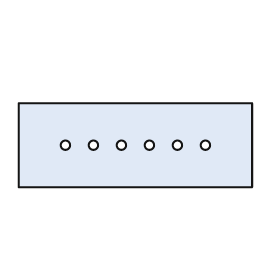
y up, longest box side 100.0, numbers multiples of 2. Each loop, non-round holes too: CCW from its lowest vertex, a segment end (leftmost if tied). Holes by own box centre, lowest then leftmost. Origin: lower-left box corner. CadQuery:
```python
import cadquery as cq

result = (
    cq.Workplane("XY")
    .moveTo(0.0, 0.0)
    .lineTo(100.0, 0.0)
    .lineTo(100.0, 36.0)
    .lineTo(0.0, 36.0)
    .close()
    .moveTo(20.0, 18.0)
    .circle(2.0)
    .moveTo(32.0, 18.0)
    .circle(2.0)
    .moveTo(44.0, 18.0)
    .circle(2.0)
    .moveTo(56.0, 18.0)
    .circle(2.0)
    .moveTo(68.0, 18.0)
    .circle(2.0)
    .moveTo(80.0, 18.0)
    .circle(2.0)
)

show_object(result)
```